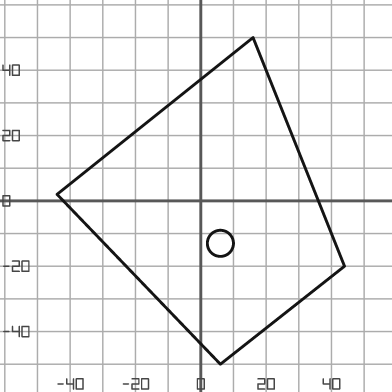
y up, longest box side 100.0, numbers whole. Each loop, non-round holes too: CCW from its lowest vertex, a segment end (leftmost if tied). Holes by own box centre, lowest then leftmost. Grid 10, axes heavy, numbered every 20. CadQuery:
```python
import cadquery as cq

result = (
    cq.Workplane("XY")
    .moveTo(6.0, -50.0)
    .lineTo(44.0, -20.0)
    .lineTo(16.0, 50.0)
    .lineTo(-44.0, 2.0)
    .close()
    .moveTo(6.0, -13.0)
    .circle(4.0)
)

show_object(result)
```